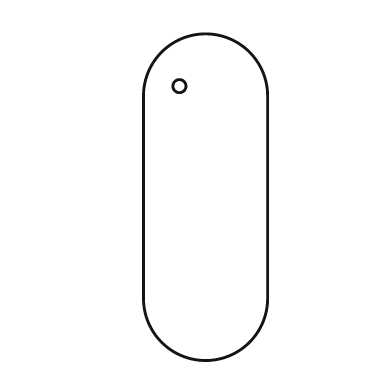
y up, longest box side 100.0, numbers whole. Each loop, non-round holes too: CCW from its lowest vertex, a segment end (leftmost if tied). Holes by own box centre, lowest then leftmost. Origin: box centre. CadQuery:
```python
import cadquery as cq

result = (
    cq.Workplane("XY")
    .moveTo(-19.0, -31.0)
    .threePointArc((0.0, -50.0), (19.0, -31.0))
    .lineTo(19.0, 31.0)
    .threePointArc((0.0, 50.0), (-19.0, 31.0))
    .close()
    .moveTo(-8.0, 34.0)
    .circle(2.0)
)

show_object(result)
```